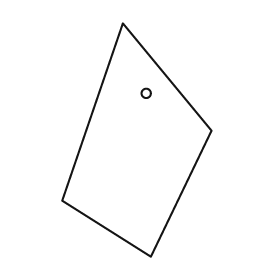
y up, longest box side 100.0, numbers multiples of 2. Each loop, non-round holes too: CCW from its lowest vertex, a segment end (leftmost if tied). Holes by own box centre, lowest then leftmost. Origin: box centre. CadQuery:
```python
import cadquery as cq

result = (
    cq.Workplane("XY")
    .moveTo(6.0, -50.0)
    .lineTo(32.0, 4.0)
    .lineTo(-6.0, 50.0)
    .lineTo(-32.0, -26.0)
    .close()
    .moveTo(4.0, 20.0)
    .circle(2.0)
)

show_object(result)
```